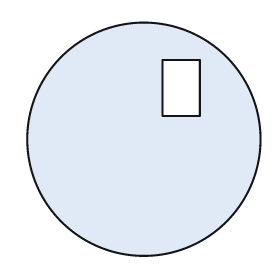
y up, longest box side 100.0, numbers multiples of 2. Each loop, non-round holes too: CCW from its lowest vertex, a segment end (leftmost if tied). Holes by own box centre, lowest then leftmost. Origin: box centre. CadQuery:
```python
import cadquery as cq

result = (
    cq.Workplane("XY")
    .moveTo(0.0, 0.0)
    .circle(50.0)
    .moveTo(8.0, 10.0)
    .lineTo(24.0, 10.0)
    .lineTo(24.0, 34.0)
    .lineTo(8.0, 34.0)
    .close()
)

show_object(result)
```